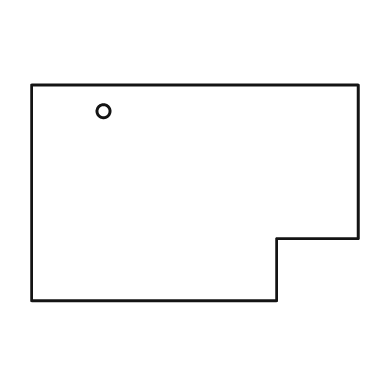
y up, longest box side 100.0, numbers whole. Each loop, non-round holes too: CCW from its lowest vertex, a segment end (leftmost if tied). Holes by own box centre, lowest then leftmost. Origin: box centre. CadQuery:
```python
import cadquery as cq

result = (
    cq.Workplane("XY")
    .moveTo(-50.0, -33.0)
    .lineTo(25.0, -33.0)
    .lineTo(25.0, -14.0)
    .lineTo(50.0, -14.0)
    .lineTo(50.0, 33.0)
    .lineTo(-50.0, 33.0)
    .close()
    .moveTo(-28.0, 25.0)
    .circle(2.0)
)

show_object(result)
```